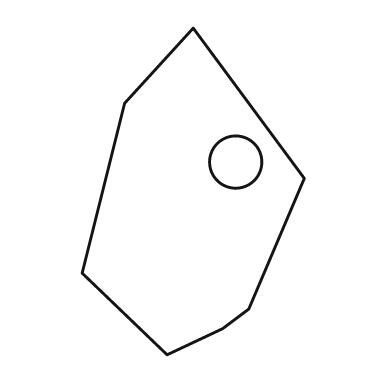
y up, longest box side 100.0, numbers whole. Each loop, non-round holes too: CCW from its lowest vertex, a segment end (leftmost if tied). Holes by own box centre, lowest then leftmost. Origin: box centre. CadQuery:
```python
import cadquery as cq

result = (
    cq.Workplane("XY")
    .moveTo(-8.0, -50.0)
    .lineTo(9.0, -42.0)
    .lineTo(17.0, -36.0)
    .lineTo(34.0, 4.0)
    .lineTo(0.0, 50.0)
    .lineTo(-21.0, 27.0)
    .lineTo(-34.0, -25.0)
    .close()
    .moveTo(13.0, 9.0)
    .circle(8.0)
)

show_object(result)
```